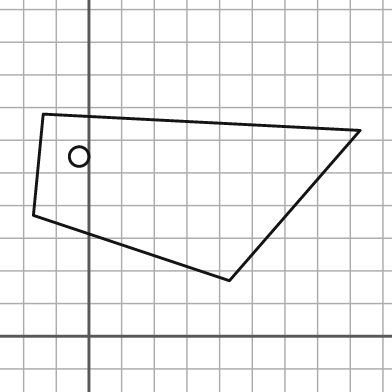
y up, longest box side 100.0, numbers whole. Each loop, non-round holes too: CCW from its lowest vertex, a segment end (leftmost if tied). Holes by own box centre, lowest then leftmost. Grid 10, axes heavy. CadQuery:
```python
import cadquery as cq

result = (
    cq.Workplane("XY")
    .moveTo(43.0, 17.0)
    .lineTo(83.0, 63.0)
    .lineTo(-14.0, 68.0)
    .lineTo(-17.0, 37.0)
    .close()
    .moveTo(-3.0, 55.0)
    .circle(3.0)
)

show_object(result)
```